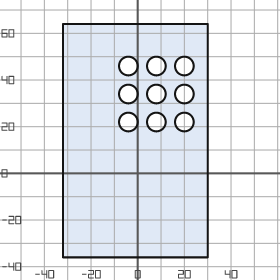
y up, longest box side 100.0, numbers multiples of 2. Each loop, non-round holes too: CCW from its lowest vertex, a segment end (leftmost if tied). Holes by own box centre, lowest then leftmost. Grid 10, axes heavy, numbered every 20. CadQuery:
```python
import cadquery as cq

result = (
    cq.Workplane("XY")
    .moveTo(-32.0, -36.0)
    .lineTo(30.0, -36.0)
    .lineTo(30.0, 64.0)
    .lineTo(-32.0, 64.0)
    .close()
    .moveTo(-4.0, 22.0)
    .circle(4.0)
    .moveTo(8.0, 22.0)
    .circle(4.0)
    .moveTo(20.0, 22.0)
    .circle(4.0)
    .moveTo(-4.0, 34.0)
    .circle(4.0)
    .moveTo(8.0, 34.0)
    .circle(4.0)
    .moveTo(20.0, 34.0)
    .circle(4.0)
    .moveTo(-4.0, 46.0)
    .circle(4.0)
    .moveTo(8.0, 46.0)
    .circle(4.0)
    .moveTo(20.0, 46.0)
    .circle(4.0)
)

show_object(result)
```